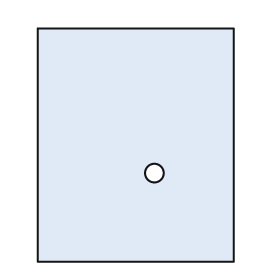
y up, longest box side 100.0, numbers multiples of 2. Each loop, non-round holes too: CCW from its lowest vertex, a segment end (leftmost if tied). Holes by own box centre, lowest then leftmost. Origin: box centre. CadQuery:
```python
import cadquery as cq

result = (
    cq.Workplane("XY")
    .moveTo(-42.0, -50.0)
    .lineTo(42.0, -50.0)
    .lineTo(42.0, 50.0)
    .lineTo(-42.0, 50.0)
    .close()
    .moveTo(8.0, -12.0)
    .circle(4.0)
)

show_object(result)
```